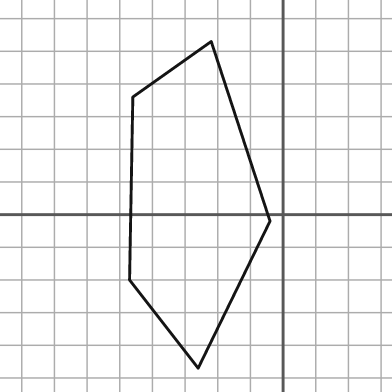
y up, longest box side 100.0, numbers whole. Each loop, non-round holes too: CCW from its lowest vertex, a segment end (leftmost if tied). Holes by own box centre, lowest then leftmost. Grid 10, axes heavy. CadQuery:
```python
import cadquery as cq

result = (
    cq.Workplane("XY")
    .moveTo(-26.0, -47.0)
    .lineTo(-4.0, -2.0)
    .lineTo(-22.0, 53.0)
    .lineTo(-46.0, 36.0)
    .lineTo(-47.0, -20.0)
    .close()
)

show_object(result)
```